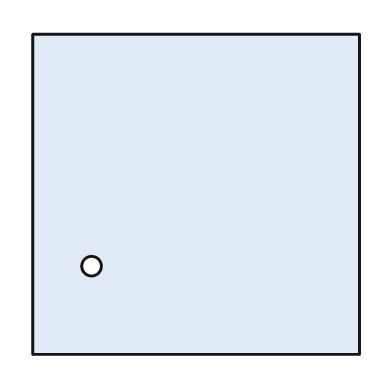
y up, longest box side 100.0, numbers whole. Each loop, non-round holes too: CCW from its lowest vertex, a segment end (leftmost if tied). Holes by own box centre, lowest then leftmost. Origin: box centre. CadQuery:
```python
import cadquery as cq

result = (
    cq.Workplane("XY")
    .moveTo(-50.0, -49.0)
    .lineTo(50.0, -49.0)
    .lineTo(50.0, 49.0)
    .lineTo(-50.0, 49.0)
    .close()
    .moveTo(-32.0, -22.0)
    .circle(3.0)
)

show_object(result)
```